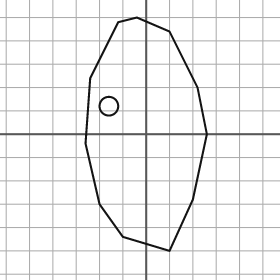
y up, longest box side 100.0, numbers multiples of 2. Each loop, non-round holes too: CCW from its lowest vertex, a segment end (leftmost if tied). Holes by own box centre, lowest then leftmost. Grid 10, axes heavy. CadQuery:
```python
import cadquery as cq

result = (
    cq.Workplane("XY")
    .moveTo(10.0, -50.0)
    .lineTo(20.0, -28.0)
    .lineTo(26.0, 0.0)
    .lineTo(22.0, 20.0)
    .lineTo(10.0, 44.0)
    .lineTo(-4.0, 50.0)
    .lineTo(-12.0, 48.0)
    .lineTo(-24.0, 24.0)
    .lineTo(-26.0, -4.0)
    .lineTo(-20.0, -30.0)
    .lineTo(-10.0, -44.0)
    .close()
    .moveTo(-16.0, 12.0)
    .circle(4.0)
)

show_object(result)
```